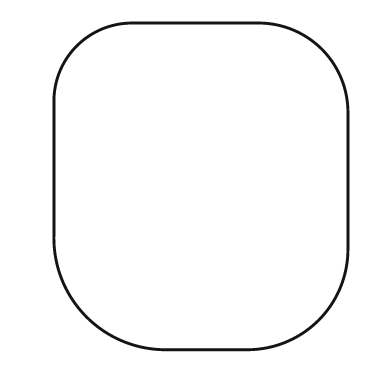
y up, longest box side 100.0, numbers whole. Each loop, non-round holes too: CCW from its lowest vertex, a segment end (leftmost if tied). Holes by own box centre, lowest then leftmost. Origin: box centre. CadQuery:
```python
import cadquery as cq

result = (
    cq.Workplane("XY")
    .moveTo(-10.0, -50.0)
    .lineTo(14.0, -50.0)
    .threePointArc((36.0, -41.0), (45.0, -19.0))
    .lineTo(45.0, 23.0)
    .threePointArc((37.0, 42.0), (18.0, 50.0))
    .lineTo(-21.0, 50.0)
    .threePointArc((-38.0, 43.0), (-45.0, 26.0))
    .lineTo(-45.0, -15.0)
    .threePointArc((-35.0, -40.0), (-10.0, -50.0))
    .close()
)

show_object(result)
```